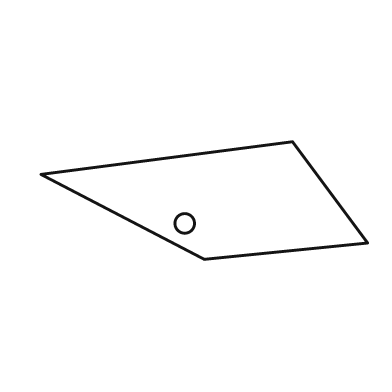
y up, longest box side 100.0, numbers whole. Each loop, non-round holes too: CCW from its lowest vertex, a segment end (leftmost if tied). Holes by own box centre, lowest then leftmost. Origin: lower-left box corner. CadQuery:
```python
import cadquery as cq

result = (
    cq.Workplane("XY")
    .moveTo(50.0, 0.0)
    .lineTo(100.0, 5.0)
    .lineTo(77.0, 36.0)
    .lineTo(0.0, 26.0)
    .close()
    .moveTo(44.0, 11.0)
    .circle(3.0)
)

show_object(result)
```